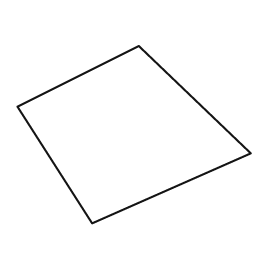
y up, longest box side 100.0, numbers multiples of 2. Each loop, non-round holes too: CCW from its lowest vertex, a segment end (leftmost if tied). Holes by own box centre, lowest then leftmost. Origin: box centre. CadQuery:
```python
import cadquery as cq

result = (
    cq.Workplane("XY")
    .moveTo(-18.0, -38.0)
    .lineTo(50.0, -8.0)
    .lineTo(2.0, 38.0)
    .lineTo(-50.0, 12.0)
    .close()
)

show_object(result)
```